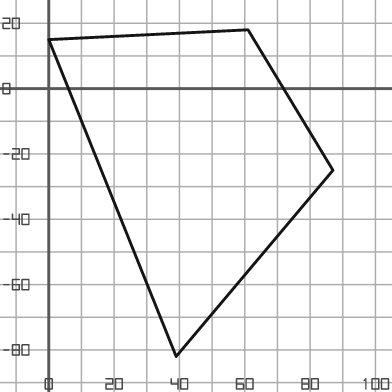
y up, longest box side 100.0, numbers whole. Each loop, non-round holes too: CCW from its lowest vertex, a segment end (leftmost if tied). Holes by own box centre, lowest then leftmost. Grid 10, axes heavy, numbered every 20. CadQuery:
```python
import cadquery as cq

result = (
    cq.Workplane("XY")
    .moveTo(39.0, -82.0)
    .lineTo(87.0, -25.0)
    .lineTo(61.0, 18.0)
    .lineTo(0.0, 15.0)
    .close()
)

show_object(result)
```